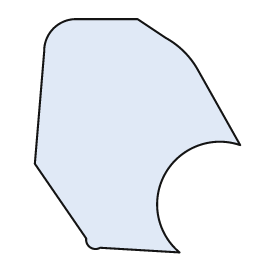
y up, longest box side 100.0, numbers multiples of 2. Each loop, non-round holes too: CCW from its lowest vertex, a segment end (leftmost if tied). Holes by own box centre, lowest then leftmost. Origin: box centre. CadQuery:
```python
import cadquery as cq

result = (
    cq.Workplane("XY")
    .moveTo(18.0, -50.0)
    .threePointArc((12.0, -16.0), (44.0, -4.0))
    .lineTo(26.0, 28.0)
    .threePointArc((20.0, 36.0), (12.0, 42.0))
    .lineTo(0.0, 50.0)
    .lineTo(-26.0, 50.0)
    .threePointArc((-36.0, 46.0), (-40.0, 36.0))
    .lineTo(-44.0, -12.0)
    .lineTo(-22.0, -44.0)
    .threePointArc((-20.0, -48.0), (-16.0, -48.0))
    .close()
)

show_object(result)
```